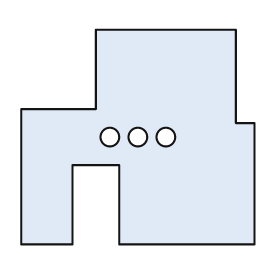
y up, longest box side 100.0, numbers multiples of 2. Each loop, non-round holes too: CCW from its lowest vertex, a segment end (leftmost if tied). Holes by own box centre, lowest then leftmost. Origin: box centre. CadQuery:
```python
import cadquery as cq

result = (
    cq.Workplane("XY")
    .moveTo(-50.0, -46.0)
    .lineTo(-28.0, -46.0)
    .lineTo(-28.0, -12.0)
    .lineTo(-8.0, -12.0)
    .lineTo(-8.0, -46.0)
    .lineTo(50.0, -46.0)
    .lineTo(50.0, 6.0)
    .lineTo(42.0, 6.0)
    .lineTo(42.0, 46.0)
    .lineTo(-18.0, 46.0)
    .lineTo(-18.0, 12.0)
    .lineTo(-50.0, 12.0)
    .close()
    .moveTo(-12.0, 0.0)
    .circle(4.0)
    .moveTo(0.0, 0.0)
    .circle(4.0)
    .moveTo(12.0, 0.0)
    .circle(4.0)
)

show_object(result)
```